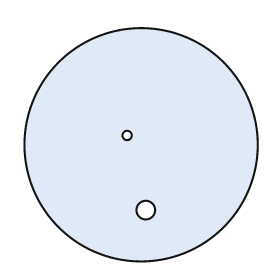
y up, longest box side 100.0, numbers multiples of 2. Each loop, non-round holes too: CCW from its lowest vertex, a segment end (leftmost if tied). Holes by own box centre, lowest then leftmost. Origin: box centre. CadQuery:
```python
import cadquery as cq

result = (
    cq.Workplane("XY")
    .moveTo(0.0, 0.0)
    .circle(50.0)
    .moveTo(2.0, -28.0)
    .circle(4.0)
    .moveTo(-6.0, 4.0)
    .circle(2.0)
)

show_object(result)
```